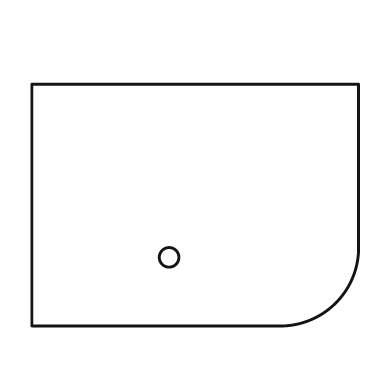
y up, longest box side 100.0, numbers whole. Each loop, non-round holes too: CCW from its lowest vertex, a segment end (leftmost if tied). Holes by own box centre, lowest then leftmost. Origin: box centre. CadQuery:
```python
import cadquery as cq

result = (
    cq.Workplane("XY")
    .moveTo(-50.0, -37.0)
    .lineTo(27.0, -37.0)
    .threePointArc((43.0, -30.0), (50.0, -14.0))
    .lineTo(50.0, 37.0)
    .lineTo(-50.0, 37.0)
    .close()
    .moveTo(-8.0, -16.0)
    .circle(3.0)
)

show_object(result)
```